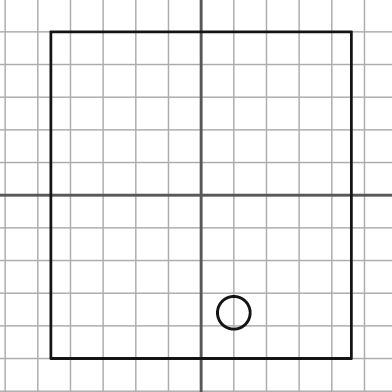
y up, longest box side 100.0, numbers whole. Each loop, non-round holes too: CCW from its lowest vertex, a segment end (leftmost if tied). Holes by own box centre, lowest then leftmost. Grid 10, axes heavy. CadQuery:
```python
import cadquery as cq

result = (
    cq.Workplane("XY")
    .moveTo(-46.0, -50.0)
    .lineTo(46.0, -50.0)
    .lineTo(46.0, 50.0)
    .lineTo(-46.0, 50.0)
    .close()
    .moveTo(10.0, -36.0)
    .circle(5.0)
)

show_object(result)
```